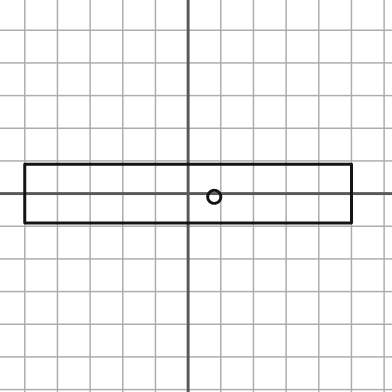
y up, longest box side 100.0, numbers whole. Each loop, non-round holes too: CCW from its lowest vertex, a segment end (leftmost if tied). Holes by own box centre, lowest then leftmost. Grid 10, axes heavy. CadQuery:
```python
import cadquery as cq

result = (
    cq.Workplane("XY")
    .moveTo(-50.0, -9.0)
    .lineTo(50.0, -9.0)
    .lineTo(50.0, 9.0)
    .lineTo(-50.0, 9.0)
    .close()
    .moveTo(8.0, -1.0)
    .circle(2.0)
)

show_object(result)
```